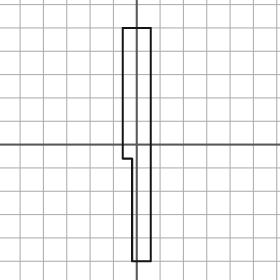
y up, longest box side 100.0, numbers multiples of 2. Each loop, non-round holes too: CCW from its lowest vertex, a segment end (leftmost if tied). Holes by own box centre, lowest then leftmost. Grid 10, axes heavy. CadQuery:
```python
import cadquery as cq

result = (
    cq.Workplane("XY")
    .moveTo(-2.0, -50.0)
    .lineTo(6.0, -50.0)
    .lineTo(6.0, 50.0)
    .lineTo(-6.0, 50.0)
    .lineTo(-6.0, -6.0)
    .lineTo(-2.0, -6.0)
    .close()
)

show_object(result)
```